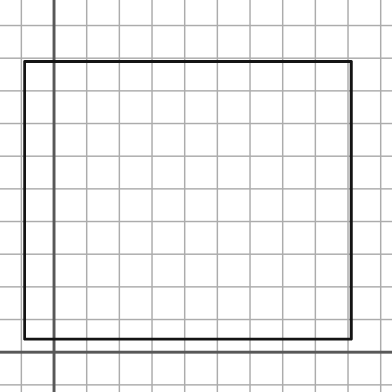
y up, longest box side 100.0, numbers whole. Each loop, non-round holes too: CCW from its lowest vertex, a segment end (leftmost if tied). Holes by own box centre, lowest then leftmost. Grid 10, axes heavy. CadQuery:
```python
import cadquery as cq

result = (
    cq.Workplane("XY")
    .moveTo(-9.0, 4.0)
    .lineTo(91.0, 4.0)
    .lineTo(91.0, 89.0)
    .lineTo(-9.0, 89.0)
    .close()
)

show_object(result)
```